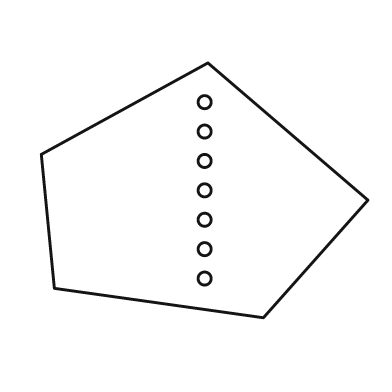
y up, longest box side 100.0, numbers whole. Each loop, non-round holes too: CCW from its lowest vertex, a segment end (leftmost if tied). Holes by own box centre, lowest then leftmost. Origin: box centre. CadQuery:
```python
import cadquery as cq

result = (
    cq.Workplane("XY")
    .moveTo(18.0, -39.0)
    .lineTo(50.0, -3.0)
    .lineTo(1.0, 39.0)
    .lineTo(-50.0, 11.0)
    .lineTo(-46.0, -30.0)
    .close()
    .moveTo(0.0, -27.0)
    .circle(2.0)
    .moveTo(0.0, -18.0)
    .circle(2.0)
    .moveTo(0.0, -9.0)
    .circle(2.0)
    .moveTo(0.0, 0.0)
    .circle(2.0)
    .moveTo(0.0, 9.0)
    .circle(2.0)
    .moveTo(0.0, 18.0)
    .circle(2.0)
    .moveTo(0.0, 27.0)
    .circle(2.0)
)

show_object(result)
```